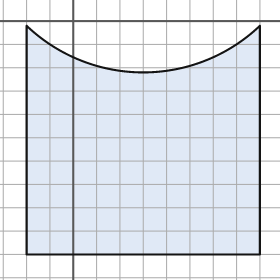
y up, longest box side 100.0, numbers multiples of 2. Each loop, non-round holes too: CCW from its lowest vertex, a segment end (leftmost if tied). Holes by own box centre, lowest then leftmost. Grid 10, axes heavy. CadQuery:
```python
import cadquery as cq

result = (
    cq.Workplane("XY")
    .moveTo(-20.0, -100.0)
    .lineTo(80.0, -100.0)
    .lineTo(80.0, -2.0)
    .threePointArc((30.0, -22.0), (-20.0, -2.0))
    .close()
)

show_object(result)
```